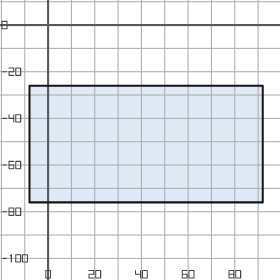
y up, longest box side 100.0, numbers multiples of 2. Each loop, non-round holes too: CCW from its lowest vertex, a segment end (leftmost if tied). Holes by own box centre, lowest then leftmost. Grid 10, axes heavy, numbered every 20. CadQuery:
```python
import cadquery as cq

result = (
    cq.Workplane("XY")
    .moveTo(-8.0, -76.0)
    .lineTo(92.0, -76.0)
    .lineTo(92.0, -26.0)
    .lineTo(-8.0, -26.0)
    .close()
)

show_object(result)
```